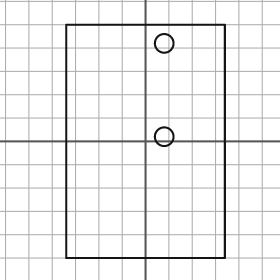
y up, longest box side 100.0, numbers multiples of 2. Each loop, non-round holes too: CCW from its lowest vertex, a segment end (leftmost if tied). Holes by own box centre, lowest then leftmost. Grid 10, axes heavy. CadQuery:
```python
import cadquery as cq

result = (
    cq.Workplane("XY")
    .moveTo(-34.0, -50.0)
    .lineTo(34.0, -50.0)
    .lineTo(34.0, 50.0)
    .lineTo(-34.0, 50.0)
    .close()
    .moveTo(8.0, 2.0)
    .circle(4.0)
    .moveTo(8.0, 42.0)
    .circle(4.0)
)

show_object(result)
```